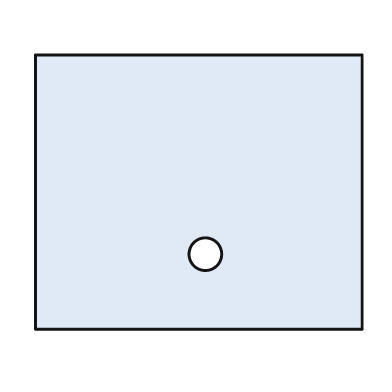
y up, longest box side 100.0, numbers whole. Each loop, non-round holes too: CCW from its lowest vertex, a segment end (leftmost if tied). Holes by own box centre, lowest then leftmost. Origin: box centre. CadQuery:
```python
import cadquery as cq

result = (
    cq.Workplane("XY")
    .moveTo(-50.0, -42.0)
    .lineTo(50.0, -42.0)
    .lineTo(50.0, 42.0)
    .lineTo(-50.0, 42.0)
    .close()
    .moveTo(2.0, -19.0)
    .circle(5.0)
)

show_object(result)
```